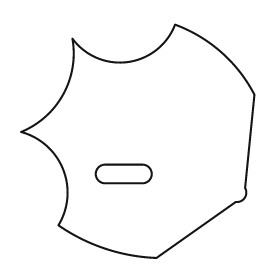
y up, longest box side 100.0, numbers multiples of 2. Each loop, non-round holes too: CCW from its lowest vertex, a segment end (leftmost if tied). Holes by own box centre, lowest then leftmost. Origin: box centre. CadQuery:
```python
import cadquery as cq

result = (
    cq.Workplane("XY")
    .moveTo(8.0, -50.0)
    .lineTo(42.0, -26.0)
    .threePointArc((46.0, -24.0), (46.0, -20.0))
    .lineTo(50.0, 20.0)
    .threePointArc((36.0, 38.0), (16.0, 50.0))
    .threePointArc((-4.0, 34.0), (-28.0, 44.0))
    .threePointArc((-32.0, 20.0), (-50.0, 4.0))
    .threePointArc((-32.0, -12.0), (-34.0, -36.0))
    .threePointArc((-14.0, -46.0), (8.0, -50.0))
    .close()
    .moveTo(-14.0, -18.0)
    .lineTo(2.0, -18.0)
    .threePointArc((6.0, -14.0), (2.0, -10.0))
    .lineTo(-14.0, -10.0)
    .threePointArc((-18.0, -14.0), (-14.0, -18.0))
    .close()
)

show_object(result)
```